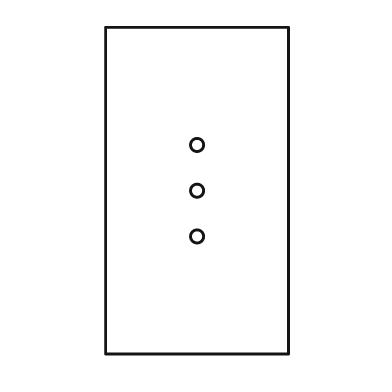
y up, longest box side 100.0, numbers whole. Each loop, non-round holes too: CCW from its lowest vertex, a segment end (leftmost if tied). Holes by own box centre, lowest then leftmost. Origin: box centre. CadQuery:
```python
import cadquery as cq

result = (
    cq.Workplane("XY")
    .moveTo(-28.0, -50.0)
    .lineTo(28.0, -50.0)
    .lineTo(28.0, 50.0)
    .lineTo(-28.0, 50.0)
    .close()
    .moveTo(0.0, -14.0)
    .circle(2.0)
    .moveTo(0.0, 0.0)
    .circle(2.0)
    .moveTo(0.0, 14.0)
    .circle(2.0)
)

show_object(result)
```